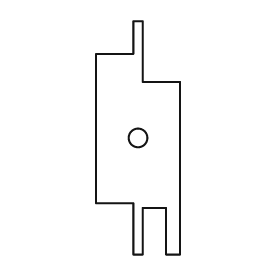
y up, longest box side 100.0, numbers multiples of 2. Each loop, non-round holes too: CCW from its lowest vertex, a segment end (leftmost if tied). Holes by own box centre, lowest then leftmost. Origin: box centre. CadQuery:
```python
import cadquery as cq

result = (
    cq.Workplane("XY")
    .moveTo(-2.0, -50.0)
    .lineTo(2.0, -50.0)
    .lineTo(2.0, -30.0)
    .lineTo(12.0, -30.0)
    .lineTo(12.0, -50.0)
    .lineTo(18.0, -50.0)
    .lineTo(18.0, 24.0)
    .lineTo(2.0, 24.0)
    .lineTo(2.0, 50.0)
    .lineTo(-2.0, 50.0)
    .lineTo(-2.0, 36.0)
    .lineTo(-18.0, 36.0)
    .lineTo(-18.0, -28.0)
    .lineTo(-2.0, -28.0)
    .close()
    .moveTo(0.0, 0.0)
    .circle(4.0)
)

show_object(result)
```